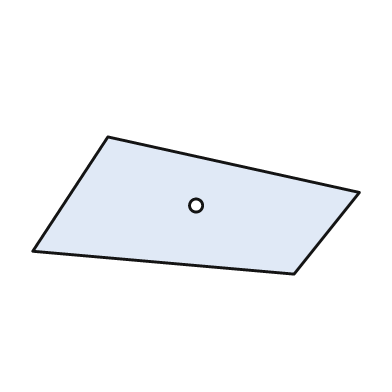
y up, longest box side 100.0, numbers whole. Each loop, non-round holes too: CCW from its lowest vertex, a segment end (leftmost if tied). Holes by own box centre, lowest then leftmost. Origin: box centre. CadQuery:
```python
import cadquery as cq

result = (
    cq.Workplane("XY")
    .moveTo(30.0, -21.0)
    .lineTo(50.0, 4.0)
    .lineTo(-27.0, 21.0)
    .lineTo(-50.0, -14.0)
    .close()
    .moveTo(0.0, 0.0)
    .circle(2.0)
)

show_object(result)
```